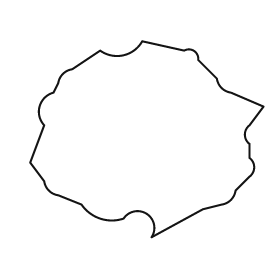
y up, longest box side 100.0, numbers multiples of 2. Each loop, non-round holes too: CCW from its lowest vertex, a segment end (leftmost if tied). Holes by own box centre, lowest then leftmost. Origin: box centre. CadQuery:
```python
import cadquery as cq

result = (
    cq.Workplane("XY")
    .moveTo(2.0, -42.0)
    .lineTo(24.0, -30.0)
    .lineTo(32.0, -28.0)
    .threePointArc((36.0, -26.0), (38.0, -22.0))
    .lineTo(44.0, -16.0)
    .threePointArc((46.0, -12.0), (44.0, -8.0))
    .lineTo(44.0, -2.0)
    .threePointArc((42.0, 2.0), (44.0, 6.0))
    .lineTo(50.0, 14.0)
    .lineTo(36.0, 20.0)
    .threePointArc((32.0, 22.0), (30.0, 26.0))
    .lineTo(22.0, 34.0)
    .threePointArc((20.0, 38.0), (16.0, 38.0))
    .lineTo(-2.0, 42.0)
    .threePointArc((-10.0, 36.0), (-20.0, 38.0))
    .lineTo(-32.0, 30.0)
    .threePointArc((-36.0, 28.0), (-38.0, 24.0))
    .lineTo(-40.0, 20.0)
    .threePointArc((-46.0, 14.0), (-44.0, 6.0))
    .lineTo(-50.0, -10.0)
    .lineTo(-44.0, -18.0)
    .threePointArc((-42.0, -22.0), (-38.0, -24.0))
    .lineTo(-28.0, -28.0)
    .threePointArc((-20.0, -34.0), (-10.0, -34.0))
    .threePointArc((0.0, -32.0), (2.0, -42.0))
    .close()
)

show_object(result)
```